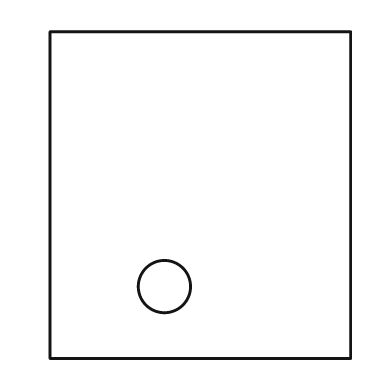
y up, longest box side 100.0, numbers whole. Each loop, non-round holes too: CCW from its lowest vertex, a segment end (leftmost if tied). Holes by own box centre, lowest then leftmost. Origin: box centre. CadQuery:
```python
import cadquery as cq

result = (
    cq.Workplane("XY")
    .moveTo(-46.0, -50.0)
    .lineTo(46.0, -50.0)
    .lineTo(46.0, 50.0)
    .lineTo(-46.0, 50.0)
    .close()
    .moveTo(-11.0, -28.0)
    .circle(8.0)
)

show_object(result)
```